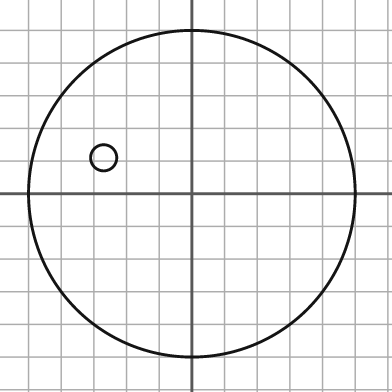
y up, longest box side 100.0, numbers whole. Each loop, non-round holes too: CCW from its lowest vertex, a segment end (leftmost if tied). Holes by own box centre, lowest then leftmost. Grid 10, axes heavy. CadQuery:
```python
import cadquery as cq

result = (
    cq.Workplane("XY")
    .moveTo(0.0, 0.0)
    .circle(50.0)
    .moveTo(-27.0, 11.0)
    .circle(4.0)
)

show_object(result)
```